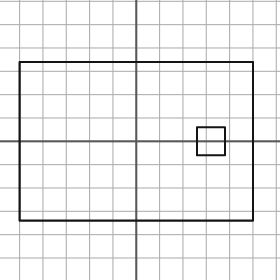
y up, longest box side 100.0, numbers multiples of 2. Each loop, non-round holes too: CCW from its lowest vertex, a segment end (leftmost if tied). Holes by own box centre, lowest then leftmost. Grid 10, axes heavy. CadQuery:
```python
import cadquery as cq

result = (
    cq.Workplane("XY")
    .moveTo(-50.0, -34.0)
    .lineTo(50.0, -34.0)
    .lineTo(50.0, 34.0)
    .lineTo(-50.0, 34.0)
    .close()
    .moveTo(26.0, -6.0)
    .lineTo(38.0, -6.0)
    .lineTo(38.0, 6.0)
    .lineTo(26.0, 6.0)
    .close()
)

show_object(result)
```